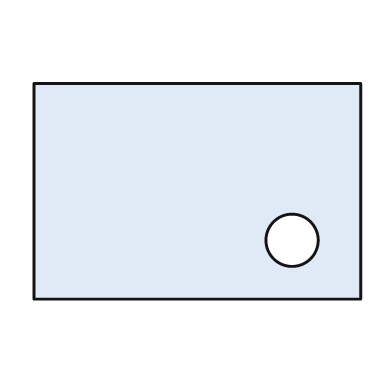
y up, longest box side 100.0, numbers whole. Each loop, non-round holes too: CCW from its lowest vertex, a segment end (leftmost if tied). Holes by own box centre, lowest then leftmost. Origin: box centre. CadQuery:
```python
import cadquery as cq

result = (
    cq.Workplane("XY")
    .moveTo(-50.0, -33.0)
    .lineTo(50.0, -33.0)
    .lineTo(50.0, 33.0)
    .lineTo(-50.0, 33.0)
    .close()
    .moveTo(29.0, -15.0)
    .circle(8.0)
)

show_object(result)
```